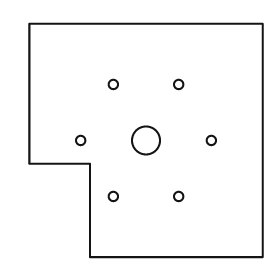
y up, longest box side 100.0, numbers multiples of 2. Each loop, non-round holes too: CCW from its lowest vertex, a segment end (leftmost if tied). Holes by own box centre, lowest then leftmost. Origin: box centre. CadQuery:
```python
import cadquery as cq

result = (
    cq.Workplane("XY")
    .moveTo(-24.0, -50.0)
    .lineTo(50.0, -50.0)
    .lineTo(50.0, 50.0)
    .lineTo(-50.0, 50.0)
    .lineTo(-50.0, -10.0)
    .lineTo(-24.0, -10.0)
    .close()
    .moveTo(-14.0, -24.0)
    .circle(2.0)
    .moveTo(14.0, -24.0)
    .circle(2.0)
    .moveTo(-28.0, 0.0)
    .circle(2.0)
    .moveTo(0.0, 0.0)
    .circle(6.0)
    .moveTo(28.0, 0.0)
    .circle(2.0)
    .moveTo(-14.0, 24.0)
    .circle(2.0)
    .moveTo(14.0, 24.0)
    .circle(2.0)
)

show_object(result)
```